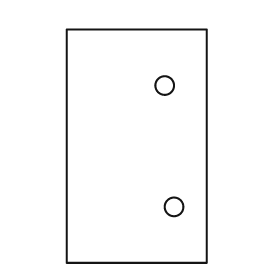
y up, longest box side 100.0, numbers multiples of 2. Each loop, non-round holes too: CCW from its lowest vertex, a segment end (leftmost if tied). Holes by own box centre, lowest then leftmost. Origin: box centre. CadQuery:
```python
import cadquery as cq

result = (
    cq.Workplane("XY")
    .moveTo(-30.0, -50.0)
    .lineTo(30.0, -50.0)
    .lineTo(30.0, 50.0)
    .lineTo(-30.0, 50.0)
    .close()
    .moveTo(16.0, -26.0)
    .circle(4.0)
    .moveTo(12.0, 26.0)
    .circle(4.0)
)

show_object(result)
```